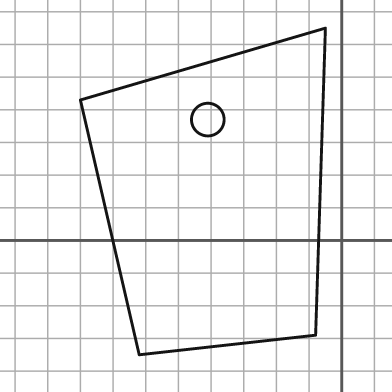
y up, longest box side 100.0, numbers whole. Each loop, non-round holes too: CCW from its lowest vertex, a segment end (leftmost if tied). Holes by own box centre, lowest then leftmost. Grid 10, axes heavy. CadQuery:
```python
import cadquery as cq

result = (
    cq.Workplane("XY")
    .moveTo(-62.0, -35.0)
    .lineTo(-8.0, -29.0)
    .lineTo(-5.0, 65.0)
    .lineTo(-80.0, 43.0)
    .close()
    .moveTo(-41.0, 37.0)
    .circle(5.0)
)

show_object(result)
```